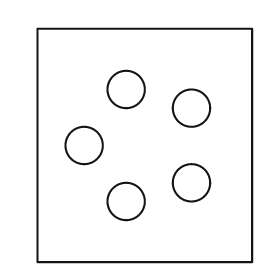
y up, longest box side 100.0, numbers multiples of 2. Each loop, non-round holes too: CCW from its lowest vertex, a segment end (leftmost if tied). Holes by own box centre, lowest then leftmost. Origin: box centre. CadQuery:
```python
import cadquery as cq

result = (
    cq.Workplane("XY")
    .moveTo(-46.0, -50.0)
    .lineTo(46.0, -50.0)
    .lineTo(46.0, 50.0)
    .lineTo(-46.0, 50.0)
    .close()
    .moveTo(-8.0, -24.0)
    .circle(8.0)
    .moveTo(20.0, -16.0)
    .circle(8.0)
    .moveTo(-26.0, 0.0)
    .circle(8.0)
    .moveTo(20.0, 16.0)
    .circle(8.0)
    .moveTo(-8.0, 24.0)
    .circle(8.0)
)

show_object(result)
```